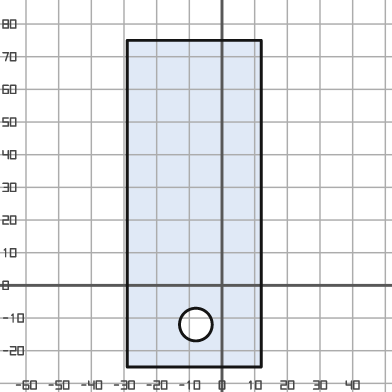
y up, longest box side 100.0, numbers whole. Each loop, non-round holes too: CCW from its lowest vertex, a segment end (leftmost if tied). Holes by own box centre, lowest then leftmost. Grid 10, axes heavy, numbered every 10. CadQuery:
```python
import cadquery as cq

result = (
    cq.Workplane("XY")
    .moveTo(-29.0, -25.0)
    .lineTo(12.0, -25.0)
    .lineTo(12.0, 75.0)
    .lineTo(-29.0, 75.0)
    .close()
    .moveTo(-8.0, -12.0)
    .circle(5.0)
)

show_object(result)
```